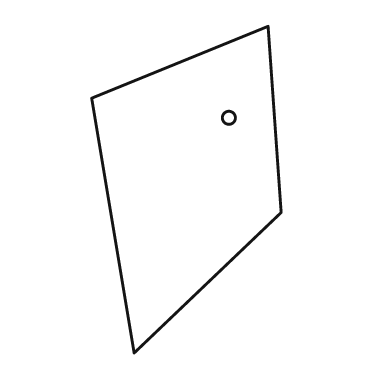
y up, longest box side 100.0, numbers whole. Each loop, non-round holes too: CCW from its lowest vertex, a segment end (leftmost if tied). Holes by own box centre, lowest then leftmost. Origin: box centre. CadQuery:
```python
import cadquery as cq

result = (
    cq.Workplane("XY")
    .moveTo(-16.0, -50.0)
    .lineTo(29.0, -7.0)
    .lineTo(25.0, 50.0)
    .lineTo(-29.0, 28.0)
    .close()
    .moveTo(13.0, 22.0)
    .circle(2.0)
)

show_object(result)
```